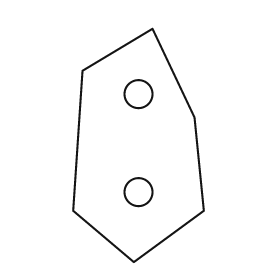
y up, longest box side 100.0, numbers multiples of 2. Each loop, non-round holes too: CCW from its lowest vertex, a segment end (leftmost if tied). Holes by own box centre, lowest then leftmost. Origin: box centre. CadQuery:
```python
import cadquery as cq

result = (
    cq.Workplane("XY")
    .moveTo(-2.0, -50.0)
    .lineTo(28.0, -28.0)
    .lineTo(24.0, 12.0)
    .lineTo(6.0, 50.0)
    .lineTo(-24.0, 32.0)
    .lineTo(-28.0, -28.0)
    .close()
    .moveTo(0.0, -20.0)
    .circle(6.0)
    .moveTo(0.0, 22.0)
    .circle(6.0)
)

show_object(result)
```